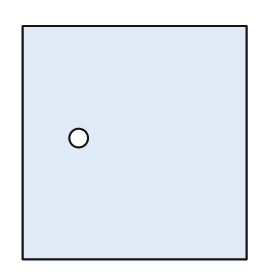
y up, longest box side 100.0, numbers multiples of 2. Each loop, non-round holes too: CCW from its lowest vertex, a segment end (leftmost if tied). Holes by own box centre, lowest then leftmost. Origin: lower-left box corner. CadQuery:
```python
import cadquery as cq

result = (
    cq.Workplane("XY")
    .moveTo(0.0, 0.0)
    .lineTo(96.0, 0.0)
    .lineTo(96.0, 100.0)
    .lineTo(0.0, 100.0)
    .close()
    .moveTo(24.0, 52.0)
    .circle(4.0)
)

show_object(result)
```